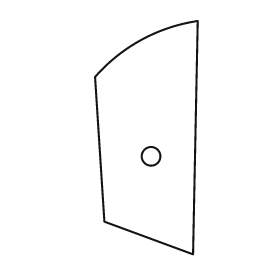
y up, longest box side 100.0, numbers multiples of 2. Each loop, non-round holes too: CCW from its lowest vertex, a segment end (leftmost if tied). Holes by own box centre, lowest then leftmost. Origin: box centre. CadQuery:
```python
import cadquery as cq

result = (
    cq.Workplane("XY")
    .moveTo(20.0, -50.0)
    .lineTo(22.0, 50.0)
    .threePointArc((-2.0, 42.0), (-22.0, 26.0))
    .lineTo(-18.0, -36.0)
    .close()
    .moveTo(2.0, -8.0)
    .circle(4.0)
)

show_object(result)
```